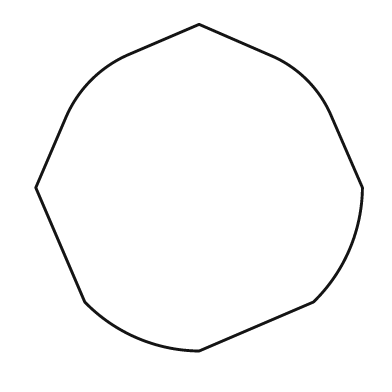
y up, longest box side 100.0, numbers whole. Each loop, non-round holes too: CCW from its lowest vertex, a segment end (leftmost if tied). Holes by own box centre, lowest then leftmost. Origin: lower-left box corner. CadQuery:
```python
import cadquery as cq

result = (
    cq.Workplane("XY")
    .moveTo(50.0, 0.0)
    .lineTo(85.0, 15.0)
    .threePointArc((96.0, 31.0), (100.0, 50.0))
    .lineTo(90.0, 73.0)
    .threePointArc((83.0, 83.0), (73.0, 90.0))
    .lineTo(50.0, 100.0)
    .lineTo(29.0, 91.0)
    .threePointArc((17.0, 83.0), (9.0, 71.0))
    .lineTo(0.0, 50.0)
    .lineTo(15.0, 15.0)
    .threePointArc((31.0, 4.0), (50.0, 0.0))
    .close()
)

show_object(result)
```